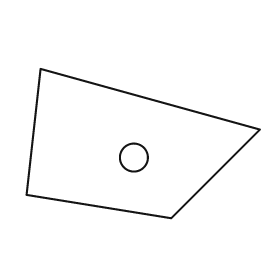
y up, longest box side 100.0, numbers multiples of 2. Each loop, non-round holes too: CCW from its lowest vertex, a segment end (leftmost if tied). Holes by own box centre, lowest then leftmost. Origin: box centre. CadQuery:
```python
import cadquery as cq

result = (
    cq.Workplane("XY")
    .moveTo(12.0, -32.0)
    .lineTo(50.0, 6.0)
    .lineTo(-44.0, 32.0)
    .lineTo(-50.0, -22.0)
    .close()
    .moveTo(-4.0, -6.0)
    .circle(6.0)
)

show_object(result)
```